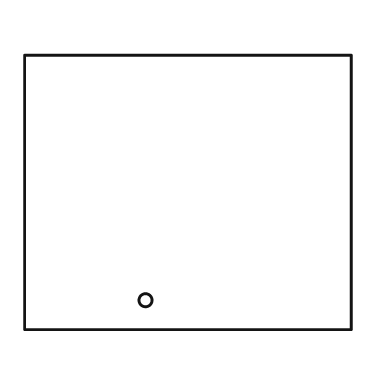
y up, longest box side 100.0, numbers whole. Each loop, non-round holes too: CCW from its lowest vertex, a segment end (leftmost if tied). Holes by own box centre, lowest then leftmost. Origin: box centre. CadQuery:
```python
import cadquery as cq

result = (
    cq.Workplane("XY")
    .moveTo(-50.0, -42.0)
    .lineTo(50.0, -42.0)
    .lineTo(50.0, 42.0)
    .lineTo(-50.0, 42.0)
    .close()
    .moveTo(-13.0, -33.0)
    .circle(2.0)
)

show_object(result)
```